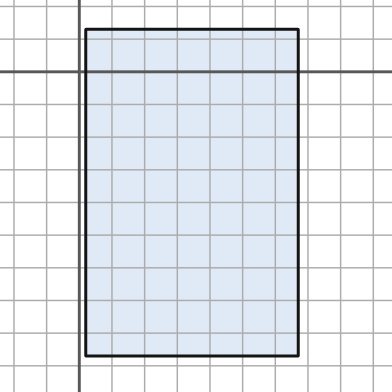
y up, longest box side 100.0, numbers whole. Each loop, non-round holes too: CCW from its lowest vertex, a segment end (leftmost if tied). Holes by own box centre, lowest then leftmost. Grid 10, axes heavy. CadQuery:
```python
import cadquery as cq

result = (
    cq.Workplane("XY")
    .moveTo(2.0, -87.0)
    .lineTo(67.0, -87.0)
    .lineTo(67.0, 13.0)
    .lineTo(2.0, 13.0)
    .close()
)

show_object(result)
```